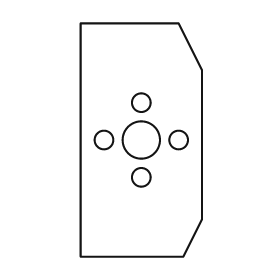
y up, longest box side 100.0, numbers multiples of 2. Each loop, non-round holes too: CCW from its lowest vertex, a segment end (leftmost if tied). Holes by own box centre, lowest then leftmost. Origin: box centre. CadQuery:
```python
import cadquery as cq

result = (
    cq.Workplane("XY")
    .moveTo(-26.0, -50.0)
    .lineTo(18.0, -50.0)
    .lineTo(26.0, -34.0)
    .lineTo(26.0, 30.0)
    .lineTo(16.0, 50.0)
    .lineTo(-26.0, 50.0)
    .close()
    .moveTo(0.0, -16.0)
    .circle(4.0)
    .moveTo(-16.0, 0.0)
    .circle(4.0)
    .moveTo(0.0, 0.0)
    .circle(8.0)
    .moveTo(16.0, 0.0)
    .circle(4.0)
    .moveTo(0.0, 16.0)
    .circle(4.0)
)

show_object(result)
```